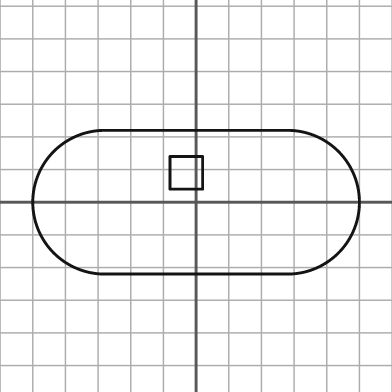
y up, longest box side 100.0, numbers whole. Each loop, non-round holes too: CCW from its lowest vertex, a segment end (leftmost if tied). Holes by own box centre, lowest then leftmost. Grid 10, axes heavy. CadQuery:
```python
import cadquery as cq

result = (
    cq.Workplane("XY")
    .moveTo(-28.0, -22.0)
    .lineTo(28.0, -22.0)
    .threePointArc((50.0, 0.0), (28.0, 22.0))
    .lineTo(-28.0, 22.0)
    .threePointArc((-50.0, 0.0), (-28.0, -22.0))
    .close()
    .moveTo(-8.0, 4.0)
    .lineTo(2.0, 4.0)
    .lineTo(2.0, 14.0)
    .lineTo(-8.0, 14.0)
    .close()
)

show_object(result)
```